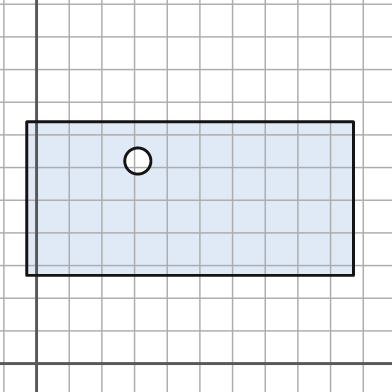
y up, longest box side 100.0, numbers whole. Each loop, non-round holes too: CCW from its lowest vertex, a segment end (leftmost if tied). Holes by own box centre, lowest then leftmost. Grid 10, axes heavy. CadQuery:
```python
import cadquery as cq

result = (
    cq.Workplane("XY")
    .moveTo(-3.0, 27.0)
    .lineTo(97.0, 27.0)
    .lineTo(97.0, 74.0)
    .lineTo(-3.0, 74.0)
    .close()
    .moveTo(31.0, 62.0)
    .circle(4.0)
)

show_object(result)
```